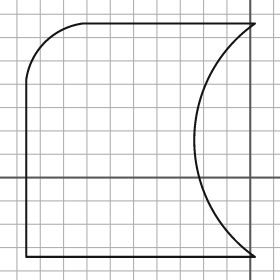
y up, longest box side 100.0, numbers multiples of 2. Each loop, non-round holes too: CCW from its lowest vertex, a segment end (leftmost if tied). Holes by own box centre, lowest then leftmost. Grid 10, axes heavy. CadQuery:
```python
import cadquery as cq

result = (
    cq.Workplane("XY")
    .moveTo(-96.0, -34.0)
    .lineTo(2.0, -34.0)
    .threePointArc((-24.0, 16.0), (2.0, 66.0))
    .lineTo(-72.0, 66.0)
    .threePointArc((-88.0, 58.0), (-96.0, 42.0))
    .close()
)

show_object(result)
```